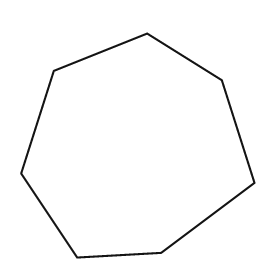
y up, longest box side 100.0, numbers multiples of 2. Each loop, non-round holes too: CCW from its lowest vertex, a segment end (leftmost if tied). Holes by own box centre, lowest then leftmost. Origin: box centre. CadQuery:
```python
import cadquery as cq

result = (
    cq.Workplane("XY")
    .moveTo(-26.0, -48.0)
    .lineTo(10.0, -46.0)
    .lineTo(50.0, -16.0)
    .lineTo(36.0, 28.0)
    .lineTo(4.0, 48.0)
    .lineTo(-36.0, 32.0)
    .lineTo(-50.0, -12.0)
    .close()
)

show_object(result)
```